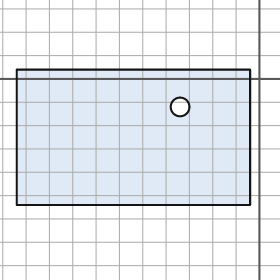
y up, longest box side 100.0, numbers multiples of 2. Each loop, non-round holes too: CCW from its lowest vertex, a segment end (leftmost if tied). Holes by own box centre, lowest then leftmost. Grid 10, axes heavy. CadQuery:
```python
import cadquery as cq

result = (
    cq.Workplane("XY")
    .moveTo(-104.0, -54.0)
    .lineTo(-4.0, -54.0)
    .lineTo(-4.0, 4.0)
    .lineTo(-104.0, 4.0)
    .close()
    .moveTo(-34.0, -12.0)
    .circle(4.0)
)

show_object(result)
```